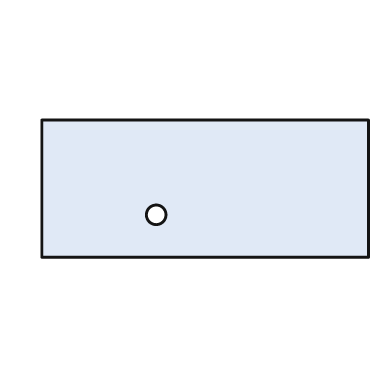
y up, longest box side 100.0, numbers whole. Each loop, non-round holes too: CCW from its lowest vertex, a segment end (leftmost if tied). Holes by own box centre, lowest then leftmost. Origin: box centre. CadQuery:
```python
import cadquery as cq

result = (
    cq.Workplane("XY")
    .moveTo(-50.0, -21.0)
    .lineTo(50.0, -21.0)
    .lineTo(50.0, 21.0)
    .lineTo(-50.0, 21.0)
    .close()
    .moveTo(-15.0, -8.0)
    .circle(3.0)
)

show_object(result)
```